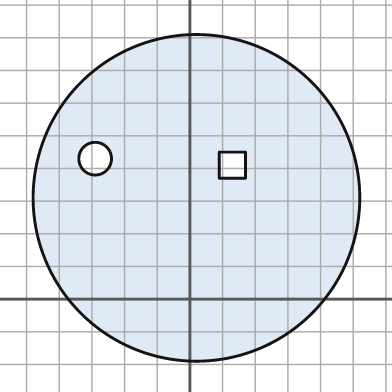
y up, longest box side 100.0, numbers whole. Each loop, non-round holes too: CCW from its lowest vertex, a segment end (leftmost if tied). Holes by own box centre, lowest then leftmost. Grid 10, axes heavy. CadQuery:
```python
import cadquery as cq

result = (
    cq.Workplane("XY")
    .moveTo(2.0, 31.0)
    .circle(50.0)
    .moveTo(9.0, 37.0)
    .lineTo(17.0, 37.0)
    .lineTo(17.0, 45.0)
    .lineTo(9.0, 45.0)
    .close()
    .moveTo(-29.0, 43.0)
    .circle(5.0)
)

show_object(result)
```